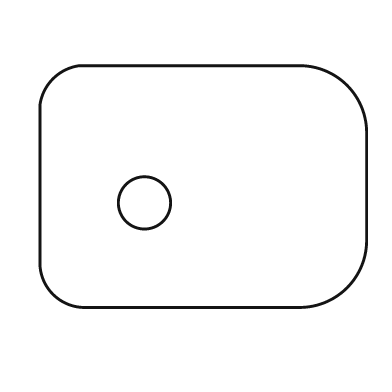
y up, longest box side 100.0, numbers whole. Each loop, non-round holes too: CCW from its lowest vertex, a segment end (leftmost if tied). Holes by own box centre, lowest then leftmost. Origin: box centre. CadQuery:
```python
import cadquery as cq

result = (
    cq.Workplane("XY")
    .moveTo(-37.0, -37.0)
    .lineTo(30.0, -37.0)
    .threePointArc((44.0, -31.0), (50.0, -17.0))
    .lineTo(50.0, 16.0)
    .threePointArc((44.0, 31.0), (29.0, 37.0))
    .lineTo(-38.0, 37.0)
    .threePointArc((-46.0, 33.0), (-50.0, 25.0))
    .lineTo(-50.0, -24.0)
    .threePointArc((-46.0, -33.0), (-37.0, -37.0))
    .close()
    .moveTo(-18.0, -5.0)
    .circle(8.0)
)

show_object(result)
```